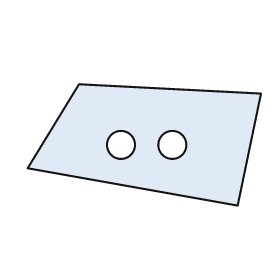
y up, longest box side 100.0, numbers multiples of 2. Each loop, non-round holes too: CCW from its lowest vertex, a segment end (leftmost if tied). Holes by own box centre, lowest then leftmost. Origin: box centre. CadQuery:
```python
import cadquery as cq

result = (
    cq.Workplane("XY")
    .moveTo(40.0, -26.0)
    .lineTo(50.0, 22.0)
    .lineTo(-28.0, 26.0)
    .lineTo(-50.0, -10.0)
    .close()
    .moveTo(-10.0, 0.0)
    .circle(6.0)
    .moveTo(12.0, 0.0)
    .circle(6.0)
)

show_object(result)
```